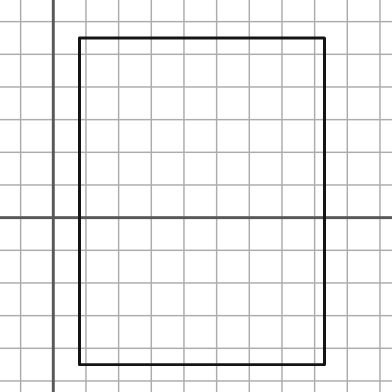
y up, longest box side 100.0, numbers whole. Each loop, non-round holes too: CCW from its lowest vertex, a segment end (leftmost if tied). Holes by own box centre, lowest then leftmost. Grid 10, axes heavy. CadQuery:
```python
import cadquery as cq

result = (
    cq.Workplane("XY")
    .moveTo(8.0, -45.0)
    .lineTo(83.0, -45.0)
    .lineTo(83.0, 55.0)
    .lineTo(8.0, 55.0)
    .close()
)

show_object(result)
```